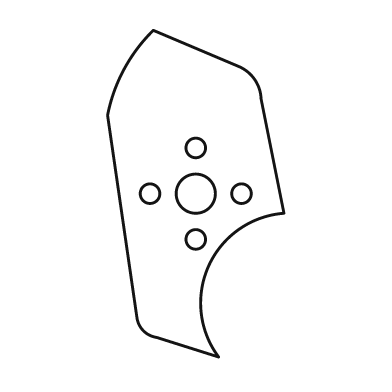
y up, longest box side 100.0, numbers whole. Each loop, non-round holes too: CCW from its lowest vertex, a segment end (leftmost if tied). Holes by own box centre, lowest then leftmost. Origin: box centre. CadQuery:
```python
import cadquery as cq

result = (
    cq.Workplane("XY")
    .moveTo(7.0, -50.0)
    .threePointArc((4.0, -22.0), (27.0, -6.0))
    .lineTo(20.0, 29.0)
    .threePointArc((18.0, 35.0), (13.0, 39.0))
    .lineTo(-13.0, 50.0)
    .threePointArc((-22.0, 38.0), (-27.0, 24.0))
    .lineTo(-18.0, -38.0)
    .threePointArc((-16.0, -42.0), (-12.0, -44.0))
    .close()
    .moveTo(0.0, -14.0)
    .circle(3.0)
    .moveTo(-14.0, 0.0)
    .circle(3.0)
    .moveTo(0.0, 0.0)
    .circle(6.0)
    .moveTo(14.0, 0.0)
    .circle(3.0)
    .moveTo(0.0, 14.0)
    .circle(3.0)
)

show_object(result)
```